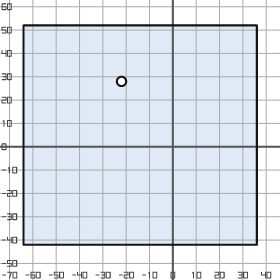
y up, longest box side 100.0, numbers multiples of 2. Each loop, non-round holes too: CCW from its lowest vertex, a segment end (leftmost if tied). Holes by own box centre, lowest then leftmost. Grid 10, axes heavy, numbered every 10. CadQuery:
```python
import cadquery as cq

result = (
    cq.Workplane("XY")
    .moveTo(-64.0, -42.0)
    .lineTo(36.0, -42.0)
    .lineTo(36.0, 52.0)
    .lineTo(-64.0, 52.0)
    .close()
    .moveTo(-22.0, 28.0)
    .circle(2.0)
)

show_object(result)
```